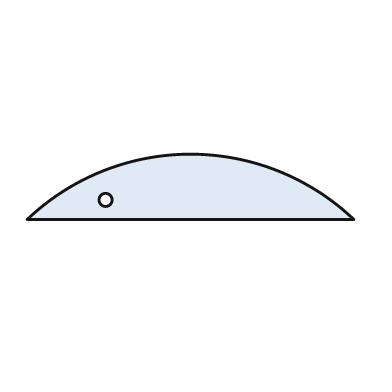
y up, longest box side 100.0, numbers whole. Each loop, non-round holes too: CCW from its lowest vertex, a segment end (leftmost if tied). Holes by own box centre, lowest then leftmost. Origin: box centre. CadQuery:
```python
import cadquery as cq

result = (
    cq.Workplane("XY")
    .moveTo(-50.0, -10.0)
    .lineTo(50.0, -10.0)
    .threePointArc((0.0, 10.0), (-50.0, -10.0))
    .close()
    .moveTo(-26.0, -4.0)
    .circle(2.0)
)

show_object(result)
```